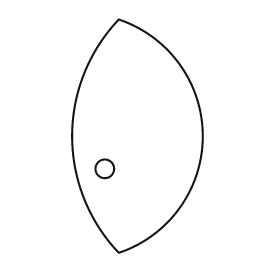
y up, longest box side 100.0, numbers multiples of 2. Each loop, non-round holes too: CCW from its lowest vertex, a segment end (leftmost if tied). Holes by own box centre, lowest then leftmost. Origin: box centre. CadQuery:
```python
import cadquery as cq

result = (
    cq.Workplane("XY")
    .moveTo(-8.0, -50.0)
    .threePointArc((28.0, 0.0), (-8.0, 50.0))
    .threePointArc((-28.0, 0.0), (-8.0, -50.0))
    .close()
    .moveTo(-14.0, -14.0)
    .circle(4.0)
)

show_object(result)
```